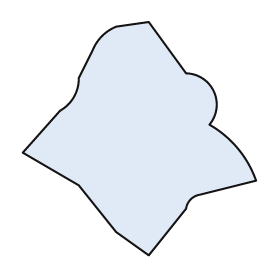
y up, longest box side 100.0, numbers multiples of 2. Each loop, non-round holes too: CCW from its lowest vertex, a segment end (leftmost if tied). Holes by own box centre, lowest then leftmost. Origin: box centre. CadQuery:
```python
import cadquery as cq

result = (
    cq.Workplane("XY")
    .moveTo(4.0, -50.0)
    .lineTo(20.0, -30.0)
    .threePointArc((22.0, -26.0), (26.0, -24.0))
    .lineTo(50.0, -18.0)
    .threePointArc((42.0, -4.0), (30.0, 6.0))
    .threePointArc((32.0, 20.0), (20.0, 28.0))
    .lineTo(4.0, 50.0)
    .lineTo(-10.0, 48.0)
    .threePointArc((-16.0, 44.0), (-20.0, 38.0))
    .lineTo(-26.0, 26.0)
    .threePointArc((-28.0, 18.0), (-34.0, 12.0))
    .lineTo(-50.0, -6.0)
    .lineTo(-26.0, -20.0)
    .lineTo(-10.0, -40.0)
    .close()
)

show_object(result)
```